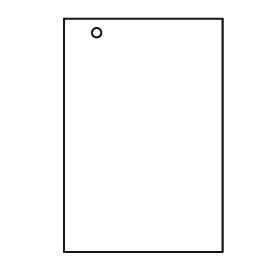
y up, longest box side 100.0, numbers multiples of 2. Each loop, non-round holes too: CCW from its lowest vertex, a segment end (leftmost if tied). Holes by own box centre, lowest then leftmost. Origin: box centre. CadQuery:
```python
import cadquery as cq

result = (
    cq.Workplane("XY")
    .moveTo(-34.0, -50.0)
    .lineTo(34.0, -50.0)
    .lineTo(34.0, 50.0)
    .lineTo(-34.0, 50.0)
    .close()
    .moveTo(-20.0, 44.0)
    .circle(2.0)
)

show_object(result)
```